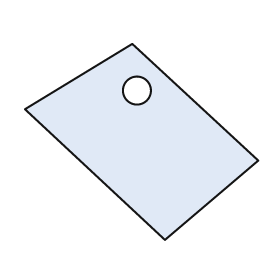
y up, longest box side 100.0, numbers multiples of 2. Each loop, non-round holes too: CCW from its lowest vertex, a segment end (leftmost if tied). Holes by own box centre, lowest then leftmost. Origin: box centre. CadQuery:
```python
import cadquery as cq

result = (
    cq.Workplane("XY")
    .moveTo(10.0, -42.0)
    .lineTo(50.0, -8.0)
    .lineTo(-4.0, 42.0)
    .lineTo(-50.0, 14.0)
    .close()
    .moveTo(-2.0, 22.0)
    .circle(6.0)
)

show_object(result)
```